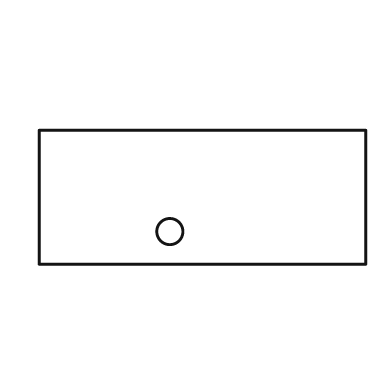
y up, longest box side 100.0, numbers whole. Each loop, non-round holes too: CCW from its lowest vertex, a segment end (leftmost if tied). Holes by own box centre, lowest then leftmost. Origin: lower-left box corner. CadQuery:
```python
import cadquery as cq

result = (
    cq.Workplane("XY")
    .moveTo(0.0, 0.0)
    .lineTo(100.0, 0.0)
    .lineTo(100.0, 41.0)
    .lineTo(0.0, 41.0)
    .close()
    .moveTo(40.0, 10.0)
    .circle(4.0)
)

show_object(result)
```